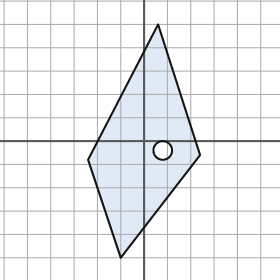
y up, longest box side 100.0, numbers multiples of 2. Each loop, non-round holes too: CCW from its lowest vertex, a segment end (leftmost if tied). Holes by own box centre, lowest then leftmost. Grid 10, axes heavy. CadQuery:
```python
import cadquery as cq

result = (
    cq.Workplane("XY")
    .moveTo(-10.0, -50.0)
    .lineTo(24.0, -6.0)
    .lineTo(6.0, 50.0)
    .lineTo(-24.0, -8.0)
    .close()
    .moveTo(8.0, -4.0)
    .circle(4.0)
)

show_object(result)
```